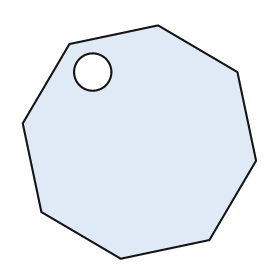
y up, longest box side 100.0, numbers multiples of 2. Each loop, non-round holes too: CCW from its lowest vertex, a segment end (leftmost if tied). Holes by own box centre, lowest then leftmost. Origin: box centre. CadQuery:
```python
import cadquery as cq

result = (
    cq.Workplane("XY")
    .moveTo(-8.0, -50.0)
    .lineTo(30.0, -42.0)
    .lineTo(50.0, -8.0)
    .lineTo(42.0, 30.0)
    .lineTo(8.0, 50.0)
    .lineTo(-30.0, 42.0)
    .lineTo(-50.0, 8.0)
    .lineTo(-42.0, -30.0)
    .close()
    .moveTo(-20.0, 30.0)
    .circle(8.0)
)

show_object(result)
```